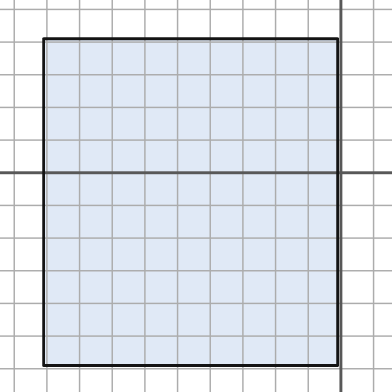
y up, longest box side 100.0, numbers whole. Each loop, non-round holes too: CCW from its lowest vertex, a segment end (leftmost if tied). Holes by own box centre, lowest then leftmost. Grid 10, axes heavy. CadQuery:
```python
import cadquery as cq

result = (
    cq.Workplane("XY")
    .moveTo(-91.0, -59.0)
    .lineTo(-1.0, -59.0)
    .lineTo(-1.0, 41.0)
    .lineTo(-91.0, 41.0)
    .close()
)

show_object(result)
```